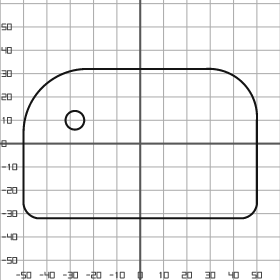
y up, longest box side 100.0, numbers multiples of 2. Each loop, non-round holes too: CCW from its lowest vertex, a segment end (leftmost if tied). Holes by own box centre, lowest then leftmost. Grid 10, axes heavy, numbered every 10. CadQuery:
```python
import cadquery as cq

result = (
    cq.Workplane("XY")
    .moveTo(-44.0, -32.0)
    .lineTo(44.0, -32.0)
    .threePointArc((48.0, -30.0), (50.0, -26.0))
    .lineTo(50.0, 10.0)
    .threePointArc((44.0, 26.0), (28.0, 32.0))
    .lineTo(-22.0, 32.0)
    .threePointArc((-42.0, 24.0), (-50.0, 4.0))
    .lineTo(-50.0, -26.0)
    .threePointArc((-48.0, -30.0), (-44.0, -32.0))
    .close()
    .moveTo(-28.0, 10.0)
    .circle(4.0)
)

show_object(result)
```